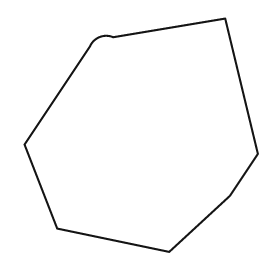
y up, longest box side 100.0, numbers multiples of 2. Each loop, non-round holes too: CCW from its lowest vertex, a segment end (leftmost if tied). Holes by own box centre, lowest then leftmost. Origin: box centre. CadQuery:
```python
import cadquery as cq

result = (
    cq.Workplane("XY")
    .moveTo(12.0, -50.0)
    .lineTo(38.0, -26.0)
    .lineTo(50.0, -8.0)
    .lineTo(36.0, 50.0)
    .lineTo(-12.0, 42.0)
    .threePointArc((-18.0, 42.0), (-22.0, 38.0))
    .lineTo(-50.0, -4.0)
    .lineTo(-36.0, -40.0)
    .close()
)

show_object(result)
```